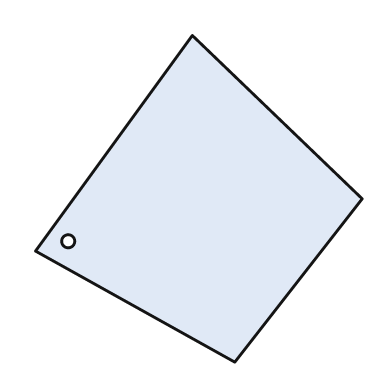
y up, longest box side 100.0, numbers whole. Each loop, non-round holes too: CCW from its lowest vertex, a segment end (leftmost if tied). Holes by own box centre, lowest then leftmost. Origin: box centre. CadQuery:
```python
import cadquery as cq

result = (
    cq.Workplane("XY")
    .moveTo(11.0, -50.0)
    .lineTo(50.0, 0.0)
    .lineTo(-2.0, 50.0)
    .lineTo(-50.0, -16.0)
    .close()
    .moveTo(-40.0, -13.0)
    .circle(2.0)
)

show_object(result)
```